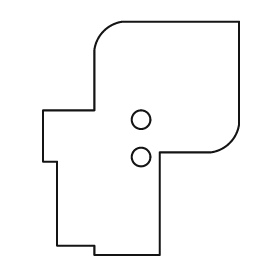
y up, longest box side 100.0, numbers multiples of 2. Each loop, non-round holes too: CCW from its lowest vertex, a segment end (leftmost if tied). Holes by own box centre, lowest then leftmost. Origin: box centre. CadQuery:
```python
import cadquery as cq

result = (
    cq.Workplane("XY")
    .moveTo(-20.0, -50.0)
    .lineTo(8.0, -50.0)
    .lineTo(8.0, -6.0)
    .lineTo(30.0, -6.0)
    .threePointArc((38.0, -2.0), (42.0, 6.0))
    .lineTo(42.0, 50.0)
    .lineTo(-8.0, 50.0)
    .threePointArc((-16.0, 46.0), (-20.0, 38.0))
    .lineTo(-20.0, 12.0)
    .lineTo(-42.0, 12.0)
    .lineTo(-42.0, -10.0)
    .lineTo(-36.0, -10.0)
    .lineTo(-36.0, -46.0)
    .lineTo(-20.0, -46.0)
    .close()
    .moveTo(0.0, -8.0)
    .circle(4.0)
    .moveTo(0.0, 8.0)
    .circle(4.0)
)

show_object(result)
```